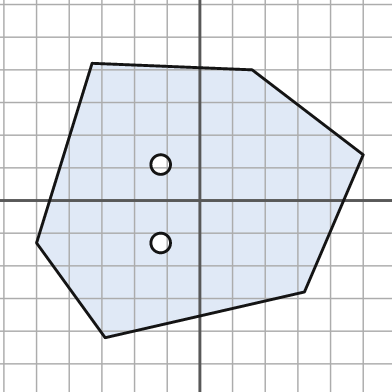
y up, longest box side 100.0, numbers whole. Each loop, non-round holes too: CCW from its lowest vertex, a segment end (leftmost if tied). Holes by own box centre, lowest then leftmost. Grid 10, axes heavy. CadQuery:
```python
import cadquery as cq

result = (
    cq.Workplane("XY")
    .moveTo(-29.0, -42.0)
    .lineTo(32.0, -28.0)
    .lineTo(50.0, 14.0)
    .lineTo(16.0, 40.0)
    .lineTo(-33.0, 42.0)
    .lineTo(-50.0, -13.0)
    .close()
    .moveTo(-12.0, -13.0)
    .circle(3.0)
    .moveTo(-12.0, 11.0)
    .circle(3.0)
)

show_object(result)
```